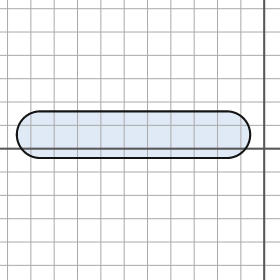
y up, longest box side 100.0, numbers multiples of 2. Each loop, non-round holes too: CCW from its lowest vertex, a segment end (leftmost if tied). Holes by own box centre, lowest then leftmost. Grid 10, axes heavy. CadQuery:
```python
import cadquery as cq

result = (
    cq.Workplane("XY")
    .moveTo(-96.0, -4.0)
    .lineTo(-16.0, -4.0)
    .threePointArc((-6.0, 6.0), (-16.0, 16.0))
    .lineTo(-96.0, 16.0)
    .threePointArc((-106.0, 6.0), (-96.0, -4.0))
    .close()
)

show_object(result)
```